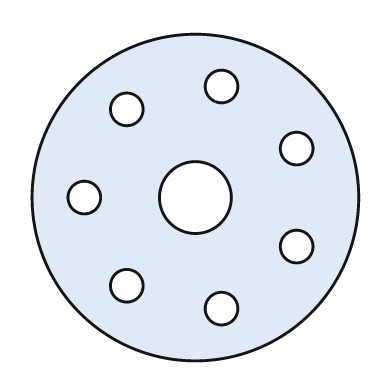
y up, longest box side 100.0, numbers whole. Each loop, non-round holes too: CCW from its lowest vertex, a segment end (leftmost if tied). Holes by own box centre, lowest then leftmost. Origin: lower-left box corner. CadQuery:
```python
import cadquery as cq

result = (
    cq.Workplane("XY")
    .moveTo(50.0, 50.0)
    .circle(50.0)
    .moveTo(58.0, 16.0)
    .circle(5.0)
    .moveTo(29.0, 23.0)
    .circle(5.0)
    .moveTo(81.0, 35.0)
    .circle(5.0)
    .moveTo(16.0, 50.0)
    .circle(5.0)
    .moveTo(50.0, 50.0)
    .circle(11.0)
    .moveTo(81.0, 65.0)
    .circle(5.0)
    .moveTo(29.0, 77.0)
    .circle(5.0)
    .moveTo(58.0, 84.0)
    .circle(5.0)
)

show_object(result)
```